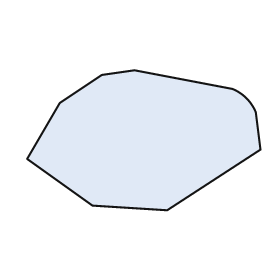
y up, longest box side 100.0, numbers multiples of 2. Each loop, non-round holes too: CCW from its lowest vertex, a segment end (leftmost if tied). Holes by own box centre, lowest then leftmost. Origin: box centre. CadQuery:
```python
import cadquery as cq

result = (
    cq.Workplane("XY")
    .moveTo(10.0, -30.0)
    .lineTo(50.0, -4.0)
    .lineTo(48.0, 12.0)
    .threePointArc((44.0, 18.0), (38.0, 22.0))
    .lineTo(-4.0, 30.0)
    .lineTo(-18.0, 28.0)
    .lineTo(-36.0, 16.0)
    .lineTo(-50.0, -8.0)
    .lineTo(-22.0, -28.0)
    .close()
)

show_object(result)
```